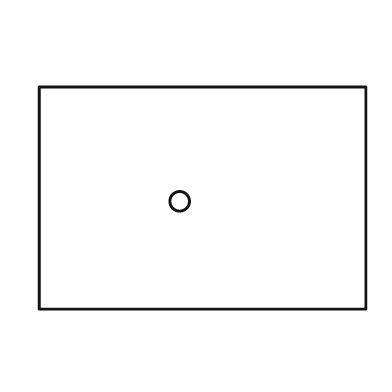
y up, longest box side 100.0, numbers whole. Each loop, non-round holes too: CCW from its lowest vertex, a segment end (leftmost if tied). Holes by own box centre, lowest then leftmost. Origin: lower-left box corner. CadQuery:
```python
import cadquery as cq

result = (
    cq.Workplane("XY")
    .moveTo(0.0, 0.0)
    .lineTo(100.0, 0.0)
    .lineTo(100.0, 68.0)
    .lineTo(0.0, 68.0)
    .close()
    .moveTo(43.0, 33.0)
    .circle(3.0)
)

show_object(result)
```